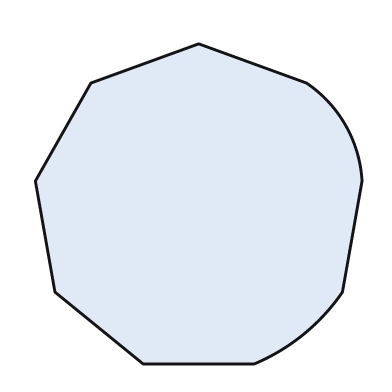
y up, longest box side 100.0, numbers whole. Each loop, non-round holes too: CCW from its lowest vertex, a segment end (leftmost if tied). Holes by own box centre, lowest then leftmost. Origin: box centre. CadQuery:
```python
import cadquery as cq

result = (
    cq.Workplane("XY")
    .moveTo(-17.0, -49.0)
    .lineTo(17.0, -49.0)
    .threePointArc((32.0, -40.0), (44.0, -27.0))
    .lineTo(50.0, 7.0)
    .threePointArc((45.0, 24.0), (33.0, 37.0))
    .lineTo(0.0, 49.0)
    .lineTo(-33.0, 37.0)
    .lineTo(-50.0, 7.0)
    .lineTo(-44.0, -27.0)
    .close()
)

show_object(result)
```